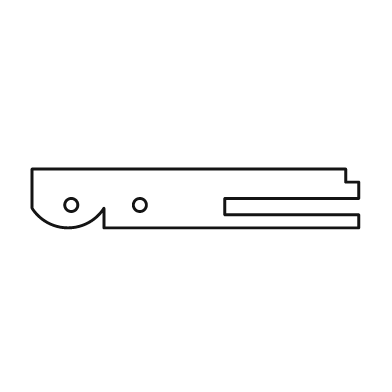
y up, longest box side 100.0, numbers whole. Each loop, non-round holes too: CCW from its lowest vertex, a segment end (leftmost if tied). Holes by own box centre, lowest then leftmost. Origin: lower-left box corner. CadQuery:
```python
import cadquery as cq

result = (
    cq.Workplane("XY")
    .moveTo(22.0, 0.0)
    .lineTo(100.0, 0.0)
    .lineTo(100.0, 4.0)
    .lineTo(59.0, 4.0)
    .lineTo(59.0, 9.0)
    .lineTo(100.0, 9.0)
    .lineTo(100.0, 14.0)
    .lineTo(96.0, 14.0)
    .lineTo(96.0, 18.0)
    .lineTo(0.0, 18.0)
    .lineTo(0.0, 6.0)
    .threePointArc((11.0, 0.0), (22.0, 6.0))
    .close()
    .moveTo(12.0, 7.0)
    .circle(2.0)
    .moveTo(33.0, 7.0)
    .circle(2.0)
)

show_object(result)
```